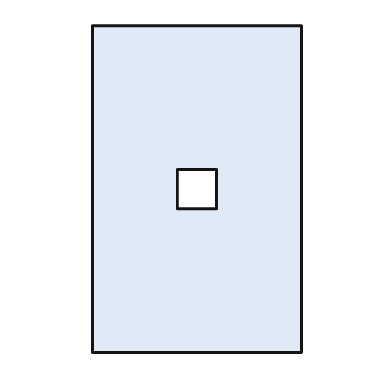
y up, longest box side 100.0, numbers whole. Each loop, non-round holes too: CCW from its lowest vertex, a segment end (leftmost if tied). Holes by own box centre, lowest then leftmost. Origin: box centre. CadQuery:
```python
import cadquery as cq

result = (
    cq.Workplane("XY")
    .moveTo(-32.0, -50.0)
    .lineTo(32.0, -50.0)
    .lineTo(32.0, 50.0)
    .lineTo(-32.0, 50.0)
    .close()
    .moveTo(-6.0, -6.0)
    .lineTo(6.0, -6.0)
    .lineTo(6.0, 6.0)
    .lineTo(-6.0, 6.0)
    .close()
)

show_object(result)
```